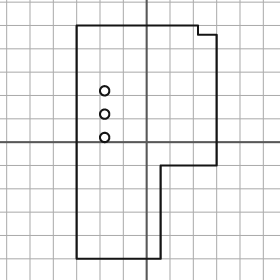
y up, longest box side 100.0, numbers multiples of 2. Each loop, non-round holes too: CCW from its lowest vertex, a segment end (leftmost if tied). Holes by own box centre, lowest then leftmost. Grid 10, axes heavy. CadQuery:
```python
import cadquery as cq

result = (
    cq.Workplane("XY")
    .moveTo(-30.0, -50.0)
    .lineTo(6.0, -50.0)
    .lineTo(6.0, -10.0)
    .lineTo(30.0, -10.0)
    .lineTo(30.0, 46.0)
    .lineTo(22.0, 46.0)
    .lineTo(22.0, 50.0)
    .lineTo(-30.0, 50.0)
    .close()
    .moveTo(-18.0, 2.0)
    .circle(2.0)
    .moveTo(-18.0, 12.0)
    .circle(2.0)
    .moveTo(-18.0, 22.0)
    .circle(2.0)
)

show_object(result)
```